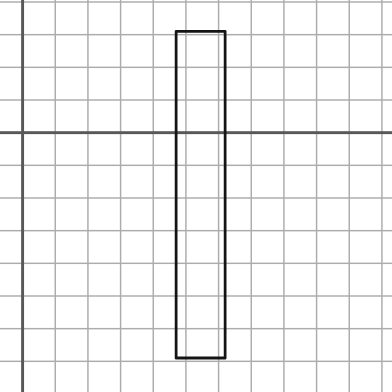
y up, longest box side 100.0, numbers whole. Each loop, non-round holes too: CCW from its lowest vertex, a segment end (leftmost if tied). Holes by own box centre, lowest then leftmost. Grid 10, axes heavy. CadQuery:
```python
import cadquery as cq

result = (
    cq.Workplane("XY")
    .moveTo(47.0, -69.0)
    .lineTo(62.0, -69.0)
    .lineTo(62.0, 31.0)
    .lineTo(47.0, 31.0)
    .close()
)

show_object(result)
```